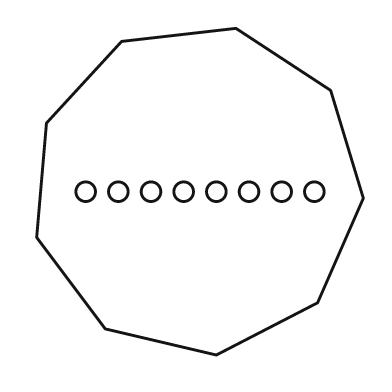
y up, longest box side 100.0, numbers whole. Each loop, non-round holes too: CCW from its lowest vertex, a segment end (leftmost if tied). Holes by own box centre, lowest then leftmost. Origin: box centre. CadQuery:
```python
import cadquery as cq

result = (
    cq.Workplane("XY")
    .moveTo(5.0, -50.0)
    .lineTo(36.0, -34.0)
    .lineTo(50.0, -2.0)
    .lineTo(40.0, 31.0)
    .lineTo(11.0, 50.0)
    .lineTo(-24.0, 46.0)
    .lineTo(-47.0, 21.0)
    .lineTo(-50.0, -14.0)
    .lineTo(-29.0, -42.0)
    .close()
    .moveTo(-35.0, 0.0)
    .circle(3.0)
    .moveTo(-25.0, 0.0)
    .circle(3.0)
    .moveTo(-15.0, 0.0)
    .circle(3.0)
    .moveTo(-5.0, 0.0)
    .circle(3.0)
    .moveTo(5.0, 0.0)
    .circle(3.0)
    .moveTo(15.0, 0.0)
    .circle(3.0)
    .moveTo(25.0, 0.0)
    .circle(3.0)
    .moveTo(35.0, 0.0)
    .circle(3.0)
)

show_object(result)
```